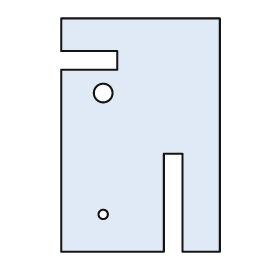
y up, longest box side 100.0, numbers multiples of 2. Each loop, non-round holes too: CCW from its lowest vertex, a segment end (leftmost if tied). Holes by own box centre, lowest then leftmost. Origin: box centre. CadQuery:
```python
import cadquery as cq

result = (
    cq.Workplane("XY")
    .moveTo(-34.0, -50.0)
    .lineTo(10.0, -50.0)
    .lineTo(10.0, -8.0)
    .lineTo(18.0, -8.0)
    .lineTo(18.0, -50.0)
    .lineTo(34.0, -50.0)
    .lineTo(34.0, 50.0)
    .lineTo(-34.0, 50.0)
    .lineTo(-34.0, 36.0)
    .lineTo(-10.0, 36.0)
    .lineTo(-10.0, 28.0)
    .lineTo(-34.0, 28.0)
    .close()
    .moveTo(-16.0, -34.0)
    .circle(2.0)
    .moveTo(-16.0, 18.0)
    .circle(4.0)
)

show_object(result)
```